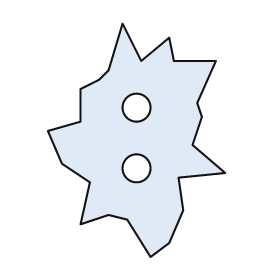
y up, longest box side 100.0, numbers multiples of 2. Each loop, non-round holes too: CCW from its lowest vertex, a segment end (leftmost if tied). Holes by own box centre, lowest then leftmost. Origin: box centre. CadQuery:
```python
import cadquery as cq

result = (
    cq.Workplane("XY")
    .moveTo(6.0, -50.0)
    .lineTo(14.0, -44.0)
    .lineTo(20.0, -30.0)
    .lineTo(18.0, -16.0)
    .lineTo(38.0, -14.0)
    .lineTo(24.0, -2.0)
    .lineTo(28.0, 10.0)
    .lineTo(26.0, 16.0)
    .lineTo(34.0, 34.0)
    .lineTo(16.0, 34.0)
    .lineTo(14.0, 44.0)
    .lineTo(2.0, 34.0)
    .lineTo(-6.0, 50.0)
    .lineTo(-12.0, 30.0)
    .lineTo(-16.0, 26.0)
    .lineTo(-24.0, 22.0)
    .lineTo(-24.0, 8.0)
    .lineTo(-38.0, 4.0)
    .lineTo(-32.0, -10.0)
    .lineTo(-20.0, -18.0)
    .lineTo(-24.0, -36.0)
    .lineTo(-12.0, -32.0)
    .lineTo(-4.0, -34.0)
    .close()
    .moveTo(0.0, -12.0)
    .circle(6.0)
    .moveTo(0.0, 14.0)
    .circle(6.0)
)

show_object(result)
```